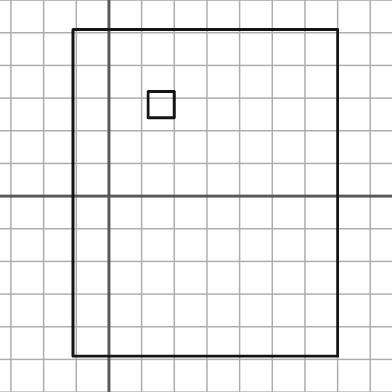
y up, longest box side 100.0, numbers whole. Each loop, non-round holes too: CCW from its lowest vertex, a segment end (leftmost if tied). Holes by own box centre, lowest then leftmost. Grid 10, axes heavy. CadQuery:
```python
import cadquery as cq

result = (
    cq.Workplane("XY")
    .moveTo(-11.0, -49.0)
    .lineTo(70.0, -49.0)
    .lineTo(70.0, 51.0)
    .lineTo(-11.0, 51.0)
    .close()
    .moveTo(12.0, 24.0)
    .lineTo(20.0, 24.0)
    .lineTo(20.0, 32.0)
    .lineTo(12.0, 32.0)
    .close()
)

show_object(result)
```